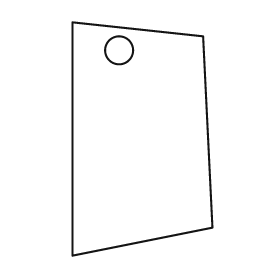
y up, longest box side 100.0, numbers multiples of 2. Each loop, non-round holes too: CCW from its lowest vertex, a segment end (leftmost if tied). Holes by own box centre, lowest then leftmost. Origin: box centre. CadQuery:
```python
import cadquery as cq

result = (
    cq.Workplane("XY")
    .moveTo(-30.0, -50.0)
    .lineTo(30.0, -38.0)
    .lineTo(26.0, 44.0)
    .lineTo(-30.0, 50.0)
    .close()
    .moveTo(-10.0, 38.0)
    .circle(6.0)
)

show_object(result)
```